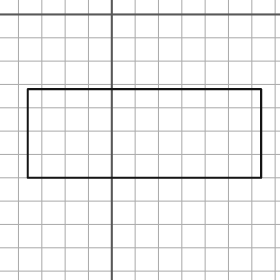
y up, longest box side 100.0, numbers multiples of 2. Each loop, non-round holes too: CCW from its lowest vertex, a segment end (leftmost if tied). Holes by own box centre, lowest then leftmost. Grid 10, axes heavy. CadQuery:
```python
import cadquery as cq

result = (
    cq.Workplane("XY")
    .moveTo(-36.0, -70.0)
    .lineTo(64.0, -70.0)
    .lineTo(64.0, -32.0)
    .lineTo(-36.0, -32.0)
    .close()
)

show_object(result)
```